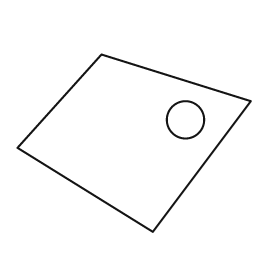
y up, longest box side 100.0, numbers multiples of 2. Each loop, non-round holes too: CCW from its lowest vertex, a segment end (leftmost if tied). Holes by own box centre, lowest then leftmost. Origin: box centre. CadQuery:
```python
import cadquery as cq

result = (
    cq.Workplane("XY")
    .moveTo(8.0, -38.0)
    .lineTo(50.0, 18.0)
    .lineTo(-14.0, 38.0)
    .lineTo(-50.0, -2.0)
    .close()
    .moveTo(22.0, 10.0)
    .circle(8.0)
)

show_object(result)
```